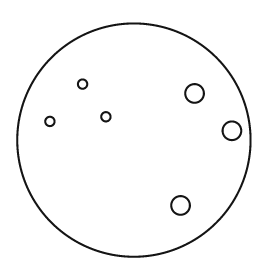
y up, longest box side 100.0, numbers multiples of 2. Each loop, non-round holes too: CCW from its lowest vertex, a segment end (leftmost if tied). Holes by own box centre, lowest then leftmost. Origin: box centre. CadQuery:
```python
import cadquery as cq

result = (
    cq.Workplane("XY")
    .moveTo(0.0, 0.0)
    .circle(50.0)
    .moveTo(20.0, -28.0)
    .circle(4.0)
    .moveTo(42.0, 4.0)
    .circle(4.0)
    .moveTo(-36.0, 8.0)
    .circle(2.0)
    .moveTo(-12.0, 10.0)
    .circle(2.0)
    .moveTo(26.0, 20.0)
    .circle(4.0)
    .moveTo(-22.0, 24.0)
    .circle(2.0)
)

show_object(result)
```